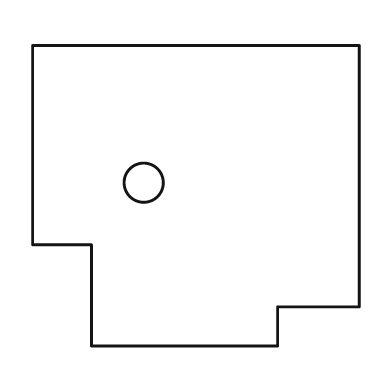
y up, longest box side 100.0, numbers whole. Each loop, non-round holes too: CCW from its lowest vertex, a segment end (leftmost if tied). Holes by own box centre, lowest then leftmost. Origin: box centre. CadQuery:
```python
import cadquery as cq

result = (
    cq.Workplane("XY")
    .moveTo(-32.0, -46.0)
    .lineTo(25.0, -46.0)
    .lineTo(25.0, -34.0)
    .lineTo(50.0, -34.0)
    .lineTo(50.0, 46.0)
    .lineTo(-50.0, 46.0)
    .lineTo(-50.0, -15.0)
    .lineTo(-32.0, -15.0)
    .close()
    .moveTo(-16.0, 4.0)
    .circle(6.0)
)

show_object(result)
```